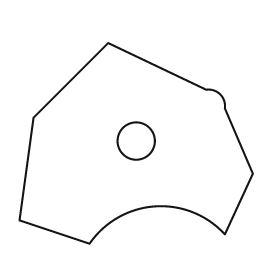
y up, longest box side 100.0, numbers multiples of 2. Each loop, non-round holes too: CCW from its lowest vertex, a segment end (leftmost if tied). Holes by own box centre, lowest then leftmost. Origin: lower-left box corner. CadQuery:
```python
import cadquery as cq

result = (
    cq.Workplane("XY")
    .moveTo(30.0, 0.0)
    .threePointArc((58.0, 16.0), (88.0, 4.0))
    .lineTo(100.0, 30.0)
    .lineTo(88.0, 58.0)
    .threePointArc((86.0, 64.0), (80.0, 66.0))
    .lineTo(38.0, 86.0)
    .lineTo(6.0, 54.0)
    .lineTo(0.0, 10.0)
    .close()
    .moveTo(50.0, 44.0)
    .circle(8.0)
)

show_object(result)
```